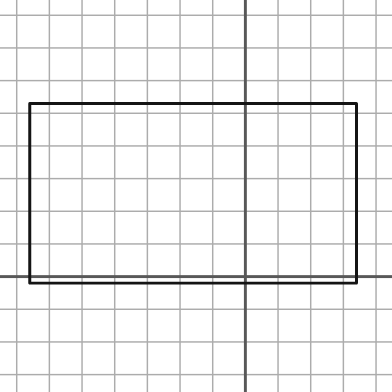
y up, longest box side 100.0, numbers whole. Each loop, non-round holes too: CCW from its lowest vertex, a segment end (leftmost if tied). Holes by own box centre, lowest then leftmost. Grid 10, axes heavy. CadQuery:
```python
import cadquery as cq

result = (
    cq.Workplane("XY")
    .moveTo(-66.0, -2.0)
    .lineTo(34.0, -2.0)
    .lineTo(34.0, 53.0)
    .lineTo(-66.0, 53.0)
    .close()
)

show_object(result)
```